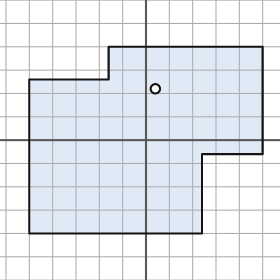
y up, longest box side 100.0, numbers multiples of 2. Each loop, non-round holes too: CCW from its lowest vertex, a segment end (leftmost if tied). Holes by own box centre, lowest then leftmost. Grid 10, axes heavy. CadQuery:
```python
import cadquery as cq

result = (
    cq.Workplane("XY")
    .moveTo(-50.0, -40.0)
    .lineTo(24.0, -40.0)
    .lineTo(24.0, -6.0)
    .lineTo(50.0, -6.0)
    .lineTo(50.0, 40.0)
    .lineTo(-16.0, 40.0)
    .lineTo(-16.0, 26.0)
    .lineTo(-50.0, 26.0)
    .close()
    .moveTo(4.0, 22.0)
    .circle(2.0)
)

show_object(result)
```